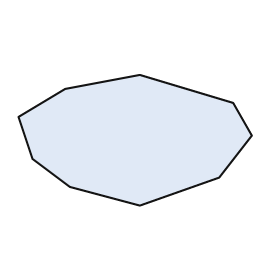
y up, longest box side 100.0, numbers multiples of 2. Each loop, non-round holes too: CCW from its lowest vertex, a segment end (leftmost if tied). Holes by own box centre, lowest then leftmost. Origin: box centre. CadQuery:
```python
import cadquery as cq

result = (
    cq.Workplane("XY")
    .moveTo(2.0, -28.0)
    .lineTo(36.0, -16.0)
    .lineTo(50.0, 2.0)
    .lineTo(42.0, 16.0)
    .lineTo(2.0, 28.0)
    .lineTo(-30.0, 22.0)
    .lineTo(-50.0, 10.0)
    .lineTo(-44.0, -8.0)
    .lineTo(-28.0, -20.0)
    .close()
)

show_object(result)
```